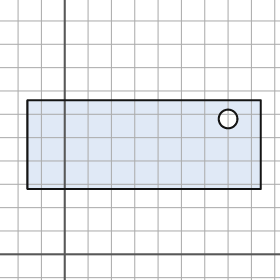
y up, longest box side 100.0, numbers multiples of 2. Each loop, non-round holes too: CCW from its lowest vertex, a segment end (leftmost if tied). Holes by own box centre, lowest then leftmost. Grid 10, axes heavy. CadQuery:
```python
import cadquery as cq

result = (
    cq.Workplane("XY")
    .moveTo(-16.0, 28.0)
    .lineTo(84.0, 28.0)
    .lineTo(84.0, 66.0)
    .lineTo(-16.0, 66.0)
    .close()
    .moveTo(70.0, 58.0)
    .circle(4.0)
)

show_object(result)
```